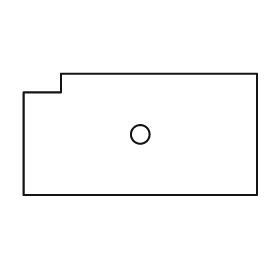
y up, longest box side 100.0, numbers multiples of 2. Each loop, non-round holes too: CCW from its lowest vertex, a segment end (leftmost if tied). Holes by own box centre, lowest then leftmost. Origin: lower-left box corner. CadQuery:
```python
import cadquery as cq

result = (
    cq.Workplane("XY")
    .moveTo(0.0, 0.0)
    .lineTo(100.0, 0.0)
    .lineTo(100.0, 52.0)
    .lineTo(16.0, 52.0)
    .lineTo(16.0, 44.0)
    .lineTo(0.0, 44.0)
    .close()
    .moveTo(50.0, 26.0)
    .circle(4.0)
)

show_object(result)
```